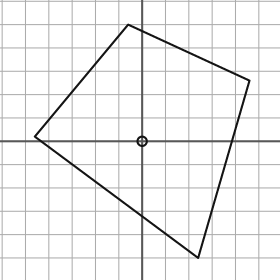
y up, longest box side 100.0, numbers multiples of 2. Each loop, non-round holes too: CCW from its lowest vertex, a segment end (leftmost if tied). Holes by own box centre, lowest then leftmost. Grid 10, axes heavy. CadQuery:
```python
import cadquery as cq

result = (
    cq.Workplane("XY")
    .moveTo(24.0, -50.0)
    .lineTo(46.0, 26.0)
    .lineTo(-6.0, 50.0)
    .lineTo(-46.0, 2.0)
    .close()
    .moveTo(0.0, 0.0)
    .circle(2.0)
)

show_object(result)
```